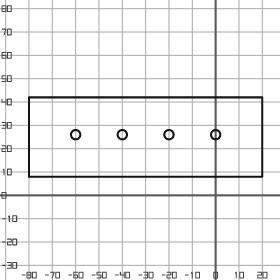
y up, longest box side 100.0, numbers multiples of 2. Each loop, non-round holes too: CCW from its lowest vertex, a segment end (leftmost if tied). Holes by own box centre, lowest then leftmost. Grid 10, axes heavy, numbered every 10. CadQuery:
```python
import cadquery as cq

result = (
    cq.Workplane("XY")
    .moveTo(-80.0, 8.0)
    .lineTo(20.0, 8.0)
    .lineTo(20.0, 42.0)
    .lineTo(-80.0, 42.0)
    .close()
    .moveTo(-60.0, 26.0)
    .circle(2.0)
    .moveTo(-40.0, 26.0)
    .circle(2.0)
    .moveTo(-20.0, 26.0)
    .circle(2.0)
    .moveTo(0.0, 26.0)
    .circle(2.0)
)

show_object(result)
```